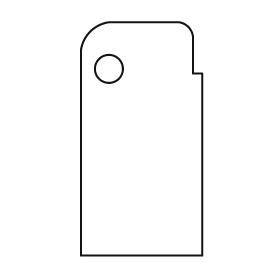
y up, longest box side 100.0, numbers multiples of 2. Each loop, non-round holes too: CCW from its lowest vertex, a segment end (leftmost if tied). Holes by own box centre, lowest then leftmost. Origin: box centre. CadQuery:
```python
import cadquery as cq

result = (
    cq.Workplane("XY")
    .moveTo(-26.0, -50.0)
    .lineTo(26.0, -50.0)
    .lineTo(26.0, 28.0)
    .lineTo(22.0, 28.0)
    .lineTo(22.0, 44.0)
    .threePointArc((20.0, 48.0), (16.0, 50.0))
    .lineTo(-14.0, 50.0)
    .threePointArc((-22.0, 46.0), (-26.0, 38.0))
    .close()
    .moveTo(-14.0, 30.0)
    .circle(6.0)
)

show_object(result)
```